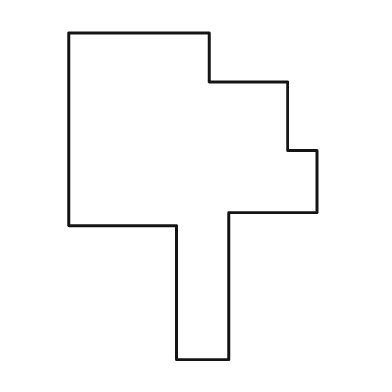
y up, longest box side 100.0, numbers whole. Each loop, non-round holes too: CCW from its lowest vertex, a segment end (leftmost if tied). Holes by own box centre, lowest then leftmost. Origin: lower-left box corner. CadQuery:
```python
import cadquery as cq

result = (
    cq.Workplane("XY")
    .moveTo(33.0, 0.0)
    .lineTo(49.0, 0.0)
    .lineTo(49.0, 45.0)
    .lineTo(76.0, 45.0)
    .lineTo(76.0, 64.0)
    .lineTo(67.0, 64.0)
    .lineTo(67.0, 85.0)
    .lineTo(43.0, 85.0)
    .lineTo(43.0, 100.0)
    .lineTo(0.0, 100.0)
    .lineTo(0.0, 41.0)
    .lineTo(33.0, 41.0)
    .close()
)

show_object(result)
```